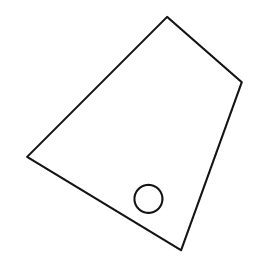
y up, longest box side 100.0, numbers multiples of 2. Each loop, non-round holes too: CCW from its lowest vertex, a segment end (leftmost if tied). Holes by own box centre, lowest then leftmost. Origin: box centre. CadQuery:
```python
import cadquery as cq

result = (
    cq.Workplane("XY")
    .moveTo(20.0, -50.0)
    .lineTo(46.0, 22.0)
    .lineTo(14.0, 50.0)
    .lineTo(-46.0, -10.0)
    .close()
    .moveTo(6.0, -28.0)
    .circle(6.0)
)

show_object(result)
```